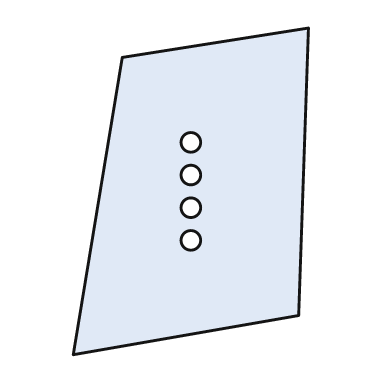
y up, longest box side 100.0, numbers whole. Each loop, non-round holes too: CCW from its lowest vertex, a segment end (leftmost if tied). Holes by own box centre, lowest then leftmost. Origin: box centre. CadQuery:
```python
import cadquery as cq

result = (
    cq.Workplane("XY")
    .moveTo(-36.0, -50.0)
    .lineTo(33.0, -38.0)
    .lineTo(36.0, 50.0)
    .lineTo(-21.0, 41.0)
    .close()
    .moveTo(0.0, -15.0)
    .circle(3.0)
    .moveTo(0.0, -5.0)
    .circle(3.0)
    .moveTo(0.0, 5.0)
    .circle(3.0)
    .moveTo(0.0, 15.0)
    .circle(3.0)
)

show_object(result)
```